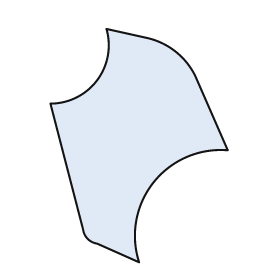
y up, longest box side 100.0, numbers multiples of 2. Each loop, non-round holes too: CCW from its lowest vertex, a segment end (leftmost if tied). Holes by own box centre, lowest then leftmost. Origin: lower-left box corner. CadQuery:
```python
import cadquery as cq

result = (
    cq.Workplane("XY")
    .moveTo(38.0, 0.0)
    .threePointArc((44.0, 34.0), (76.0, 48.0))
    .lineTo(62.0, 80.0)
    .threePointArc((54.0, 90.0), (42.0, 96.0))
    .lineTo(24.0, 100.0)
    .threePointArc((20.0, 78.0), (0.0, 68.0))
    .lineTo(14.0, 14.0)
    .threePointArc((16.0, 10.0), (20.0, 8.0))
    .close()
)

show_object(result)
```